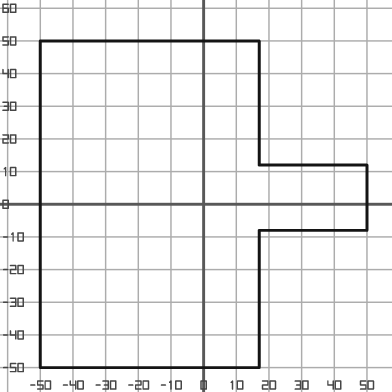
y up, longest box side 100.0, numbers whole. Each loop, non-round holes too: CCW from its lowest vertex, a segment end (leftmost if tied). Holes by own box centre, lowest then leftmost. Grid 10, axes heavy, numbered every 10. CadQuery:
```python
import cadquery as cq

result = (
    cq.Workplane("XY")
    .moveTo(-50.0, -50.0)
    .lineTo(17.0, -50.0)
    .lineTo(17.0, -8.0)
    .lineTo(50.0, -8.0)
    .lineTo(50.0, 12.0)
    .lineTo(17.0, 12.0)
    .lineTo(17.0, 50.0)
    .lineTo(-50.0, 50.0)
    .close()
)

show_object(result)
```